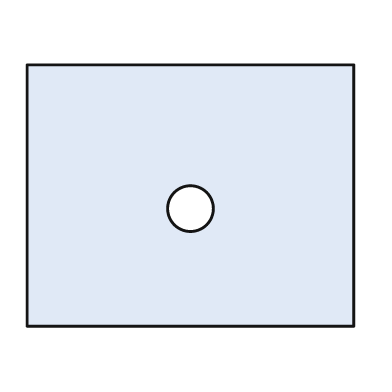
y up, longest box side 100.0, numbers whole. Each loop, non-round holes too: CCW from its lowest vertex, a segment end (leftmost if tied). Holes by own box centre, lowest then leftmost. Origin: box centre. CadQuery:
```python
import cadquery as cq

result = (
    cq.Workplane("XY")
    .moveTo(-50.0, -40.0)
    .lineTo(50.0, -40.0)
    .lineTo(50.0, 40.0)
    .lineTo(-50.0, 40.0)
    .close()
    .moveTo(0.0, -4.0)
    .circle(7.0)
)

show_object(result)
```